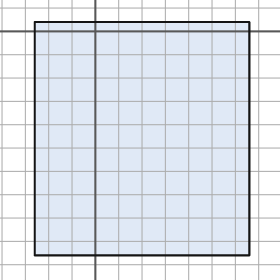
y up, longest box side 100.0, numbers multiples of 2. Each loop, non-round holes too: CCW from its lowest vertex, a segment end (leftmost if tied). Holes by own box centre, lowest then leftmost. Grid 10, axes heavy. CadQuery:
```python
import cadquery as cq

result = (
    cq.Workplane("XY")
    .moveTo(-26.0, -96.0)
    .lineTo(66.0, -96.0)
    .lineTo(66.0, 4.0)
    .lineTo(-26.0, 4.0)
    .close()
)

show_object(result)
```